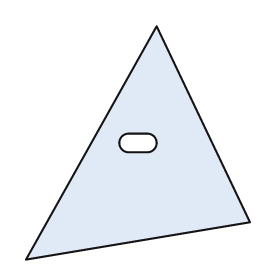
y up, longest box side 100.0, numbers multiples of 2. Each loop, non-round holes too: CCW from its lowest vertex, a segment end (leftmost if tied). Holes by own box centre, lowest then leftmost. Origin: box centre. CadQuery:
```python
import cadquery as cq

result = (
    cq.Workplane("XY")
    .moveTo(-48.0, -50.0)
    .lineTo(48.0, -34.0)
    .lineTo(8.0, 50.0)
    .close()
    .moveTo(-4.0, -4.0)
    .lineTo(4.0, -4.0)
    .threePointArc((8.0, 0.0), (4.0, 4.0))
    .lineTo(-4.0, 4.0)
    .threePointArc((-8.0, 0.0), (-4.0, -4.0))
    .close()
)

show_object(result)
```